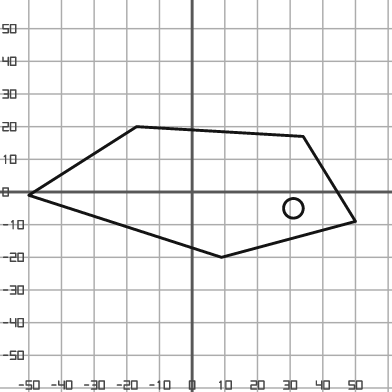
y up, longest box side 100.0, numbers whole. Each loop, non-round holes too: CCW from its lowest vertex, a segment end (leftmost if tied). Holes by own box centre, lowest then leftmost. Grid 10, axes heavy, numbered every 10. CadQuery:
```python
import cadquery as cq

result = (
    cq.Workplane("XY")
    .moveTo(9.0, -20.0)
    .lineTo(50.0, -9.0)
    .lineTo(34.0, 17.0)
    .lineTo(-17.0, 20.0)
    .lineTo(-50.0, -1.0)
    .close()
    .moveTo(31.0, -5.0)
    .circle(3.0)
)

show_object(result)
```